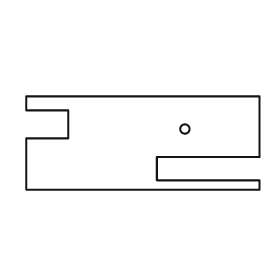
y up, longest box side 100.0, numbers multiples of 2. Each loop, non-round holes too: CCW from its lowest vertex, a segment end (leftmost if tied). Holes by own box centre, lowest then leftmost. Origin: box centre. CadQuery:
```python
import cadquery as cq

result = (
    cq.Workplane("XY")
    .moveTo(-50.0, -20.0)
    .lineTo(50.0, -20.0)
    .lineTo(50.0, -16.0)
    .lineTo(6.0, -16.0)
    .lineTo(6.0, -6.0)
    .lineTo(50.0, -6.0)
    .lineTo(50.0, 20.0)
    .lineTo(-50.0, 20.0)
    .lineTo(-50.0, 14.0)
    .lineTo(-32.0, 14.0)
    .lineTo(-32.0, 2.0)
    .lineTo(-50.0, 2.0)
    .close()
    .moveTo(18.0, 6.0)
    .circle(2.0)
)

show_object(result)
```